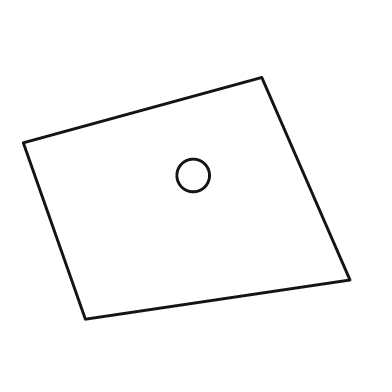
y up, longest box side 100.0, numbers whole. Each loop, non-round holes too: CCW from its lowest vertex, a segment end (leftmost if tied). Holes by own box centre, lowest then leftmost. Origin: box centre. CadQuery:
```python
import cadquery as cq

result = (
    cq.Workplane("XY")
    .moveTo(-31.0, -37.0)
    .lineTo(50.0, -25.0)
    .lineTo(23.0, 37.0)
    .lineTo(-50.0, 17.0)
    .close()
    .moveTo(2.0, 7.0)
    .circle(5.0)
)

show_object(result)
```